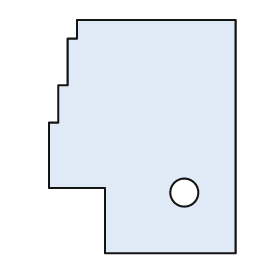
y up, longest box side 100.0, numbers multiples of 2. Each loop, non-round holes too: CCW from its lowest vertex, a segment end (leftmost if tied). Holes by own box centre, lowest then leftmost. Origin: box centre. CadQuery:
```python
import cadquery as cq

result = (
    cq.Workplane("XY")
    .moveTo(-16.0, -50.0)
    .lineTo(40.0, -50.0)
    .lineTo(40.0, 50.0)
    .lineTo(-28.0, 50.0)
    .lineTo(-28.0, 42.0)
    .lineTo(-32.0, 42.0)
    .lineTo(-32.0, 22.0)
    .lineTo(-36.0, 22.0)
    .lineTo(-36.0, 6.0)
    .lineTo(-40.0, 6.0)
    .lineTo(-40.0, -22.0)
    .lineTo(-16.0, -22.0)
    .close()
    .moveTo(18.0, -24.0)
    .circle(6.0)
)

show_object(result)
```